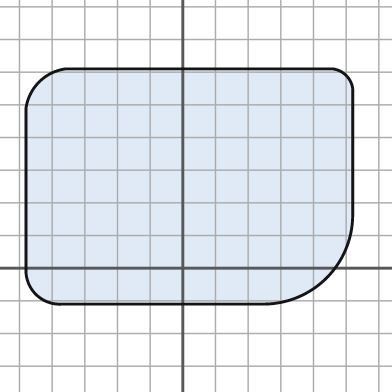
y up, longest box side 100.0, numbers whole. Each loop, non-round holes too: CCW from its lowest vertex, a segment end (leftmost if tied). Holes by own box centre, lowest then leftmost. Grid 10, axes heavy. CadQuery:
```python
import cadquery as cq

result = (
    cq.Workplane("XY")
    .moveTo(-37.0, -11.0)
    .lineTo(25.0, -11.0)
    .threePointArc((44.0, -3.0), (52.0, 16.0))
    .lineTo(52.0, 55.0)
    .threePointArc((50.0, 59.0), (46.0, 61.0))
    .lineTo(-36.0, 61.0)
    .threePointArc((-44.0, 57.0), (-48.0, 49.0))
    .lineTo(-48.0, 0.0)
    .threePointArc((-45.0, -8.0), (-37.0, -11.0))
    .close()
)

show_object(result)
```